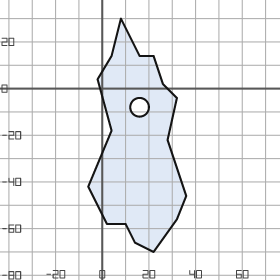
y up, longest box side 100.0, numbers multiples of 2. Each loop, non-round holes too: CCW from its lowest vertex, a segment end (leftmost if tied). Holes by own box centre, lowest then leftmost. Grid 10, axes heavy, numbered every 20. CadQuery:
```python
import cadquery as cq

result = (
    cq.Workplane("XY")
    .moveTo(22.0, -70.0)
    .lineTo(32.0, -56.0)
    .lineTo(36.0, -46.0)
    .lineTo(28.0, -22.0)
    .lineTo(32.0, -4.0)
    .lineTo(26.0, 2.0)
    .lineTo(22.0, 14.0)
    .lineTo(16.0, 14.0)
    .lineTo(8.0, 30.0)
    .lineTo(4.0, 14.0)
    .lineTo(-2.0, 4.0)
    .lineTo(4.0, -18.0)
    .lineTo(-6.0, -42.0)
    .lineTo(2.0, -58.0)
    .lineTo(10.0, -58.0)
    .lineTo(14.0, -66.0)
    .close()
    .moveTo(16.0, -8.0)
    .circle(4.0)
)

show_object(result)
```